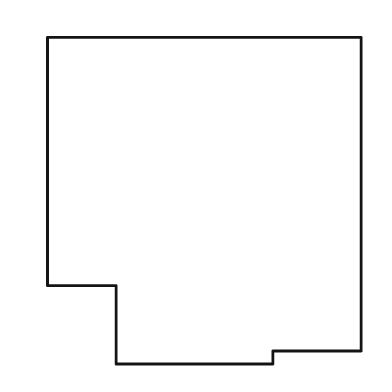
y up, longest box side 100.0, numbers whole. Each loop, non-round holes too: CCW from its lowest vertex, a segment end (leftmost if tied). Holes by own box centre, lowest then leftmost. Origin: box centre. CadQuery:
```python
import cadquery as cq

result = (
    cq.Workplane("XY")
    .moveTo(-27.0, -50.0)
    .lineTo(21.0, -50.0)
    .lineTo(21.0, -46.0)
    .lineTo(48.0, -46.0)
    .lineTo(48.0, 50.0)
    .lineTo(-48.0, 50.0)
    .lineTo(-48.0, -26.0)
    .lineTo(-27.0, -26.0)
    .close()
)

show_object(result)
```